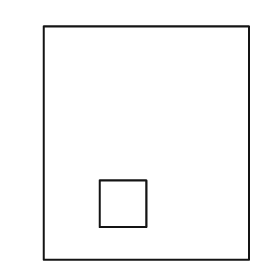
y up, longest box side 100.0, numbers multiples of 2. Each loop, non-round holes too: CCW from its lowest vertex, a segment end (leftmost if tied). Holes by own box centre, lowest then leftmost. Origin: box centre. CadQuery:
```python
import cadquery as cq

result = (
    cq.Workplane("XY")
    .moveTo(-44.0, -50.0)
    .lineTo(44.0, -50.0)
    .lineTo(44.0, 50.0)
    .lineTo(-44.0, 50.0)
    .close()
    .moveTo(-20.0, -36.0)
    .lineTo(0.0, -36.0)
    .lineTo(0.0, -16.0)
    .lineTo(-20.0, -16.0)
    .close()
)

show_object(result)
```